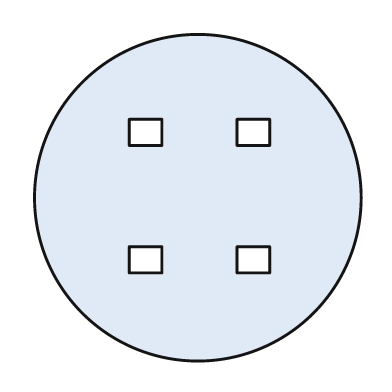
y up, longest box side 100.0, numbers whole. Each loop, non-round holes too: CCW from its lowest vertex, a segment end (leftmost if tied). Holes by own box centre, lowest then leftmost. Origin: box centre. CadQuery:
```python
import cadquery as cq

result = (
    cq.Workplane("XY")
    .moveTo(0.0, 0.0)
    .circle(50.0)
    .moveTo(-21.0, -23.0)
    .lineTo(-11.0, -23.0)
    .lineTo(-11.0, -15.0)
    .lineTo(-21.0, -15.0)
    .close()
    .moveTo(12.0, -23.0)
    .lineTo(22.0, -23.0)
    .lineTo(22.0, -15.0)
    .lineTo(12.0, -15.0)
    .close()
    .moveTo(-21.0, 16.0)
    .lineTo(-11.0, 16.0)
    .lineTo(-11.0, 24.0)
    .lineTo(-21.0, 24.0)
    .close()
    .moveTo(12.0, 16.0)
    .lineTo(22.0, 16.0)
    .lineTo(22.0, 24.0)
    .lineTo(12.0, 24.0)
    .close()
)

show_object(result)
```